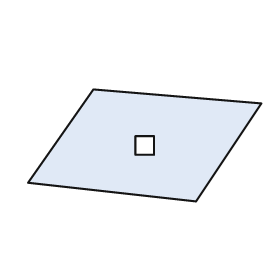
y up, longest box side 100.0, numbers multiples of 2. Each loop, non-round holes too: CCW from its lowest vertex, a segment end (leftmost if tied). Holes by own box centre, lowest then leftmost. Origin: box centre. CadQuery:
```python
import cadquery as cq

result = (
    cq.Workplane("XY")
    .moveTo(22.0, -24.0)
    .lineTo(50.0, 18.0)
    .lineTo(-22.0, 24.0)
    .lineTo(-50.0, -16.0)
    .close()
    .moveTo(-4.0, -4.0)
    .lineTo(4.0, -4.0)
    .lineTo(4.0, 4.0)
    .lineTo(-4.0, 4.0)
    .close()
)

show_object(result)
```